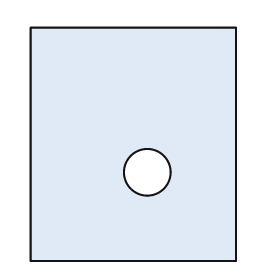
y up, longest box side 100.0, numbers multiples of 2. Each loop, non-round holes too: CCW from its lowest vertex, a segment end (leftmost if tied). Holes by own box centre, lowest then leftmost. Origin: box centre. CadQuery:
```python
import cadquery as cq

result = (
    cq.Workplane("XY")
    .moveTo(-44.0, -50.0)
    .lineTo(44.0, -50.0)
    .lineTo(44.0, 50.0)
    .lineTo(-44.0, 50.0)
    .close()
    .moveTo(6.0, -12.0)
    .circle(10.0)
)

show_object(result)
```